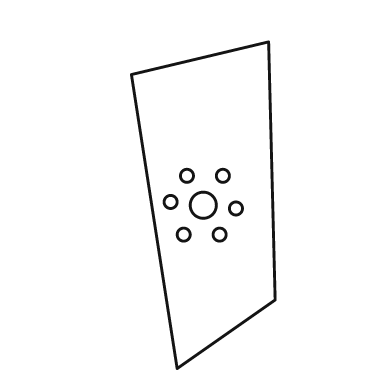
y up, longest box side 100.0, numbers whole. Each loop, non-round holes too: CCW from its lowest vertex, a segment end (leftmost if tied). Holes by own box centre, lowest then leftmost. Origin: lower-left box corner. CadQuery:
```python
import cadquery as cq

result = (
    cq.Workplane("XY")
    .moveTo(14.0, 0.0)
    .lineTo(44.0, 21.0)
    .lineTo(42.0, 100.0)
    .lineTo(0.0, 90.0)
    .close()
    .moveTo(16.0, 41.0)
    .circle(2.0)
    .moveTo(27.0, 41.0)
    .circle(2.0)
    .moveTo(32.0, 49.0)
    .circle(2.0)
    .moveTo(22.0, 50.0)
    .circle(4.0)
    .moveTo(12.0, 51.0)
    .circle(2.0)
    .moveTo(17.0, 59.0)
    .circle(2.0)
    .moveTo(28.0, 59.0)
    .circle(2.0)
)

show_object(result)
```